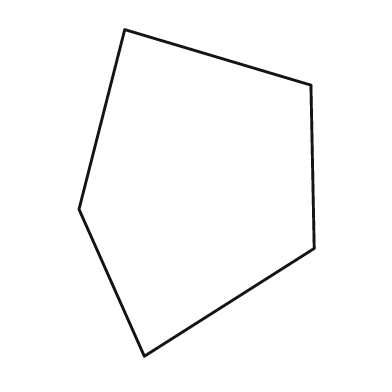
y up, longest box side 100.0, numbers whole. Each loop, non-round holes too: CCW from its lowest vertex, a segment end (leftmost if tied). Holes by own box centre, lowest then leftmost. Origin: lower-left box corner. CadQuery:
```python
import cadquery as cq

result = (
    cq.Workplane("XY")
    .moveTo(20.0, 0.0)
    .lineTo(72.0, 33.0)
    .lineTo(71.0, 83.0)
    .lineTo(14.0, 100.0)
    .lineTo(0.0, 45.0)
    .close()
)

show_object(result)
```